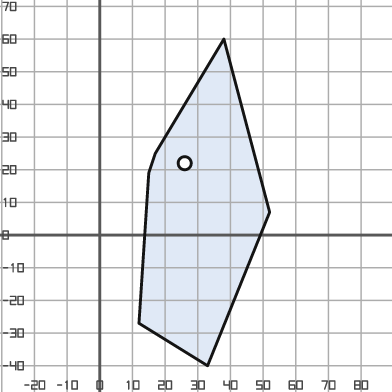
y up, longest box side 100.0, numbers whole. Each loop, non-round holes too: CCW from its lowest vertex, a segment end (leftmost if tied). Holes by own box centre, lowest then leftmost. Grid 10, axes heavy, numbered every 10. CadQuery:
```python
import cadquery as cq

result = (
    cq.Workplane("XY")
    .moveTo(33.0, -40.0)
    .lineTo(52.0, 7.0)
    .lineTo(38.0, 60.0)
    .lineTo(17.0, 25.0)
    .lineTo(15.0, 19.0)
    .lineTo(12.0, -27.0)
    .close()
    .moveTo(26.0, 22.0)
    .circle(2.0)
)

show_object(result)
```